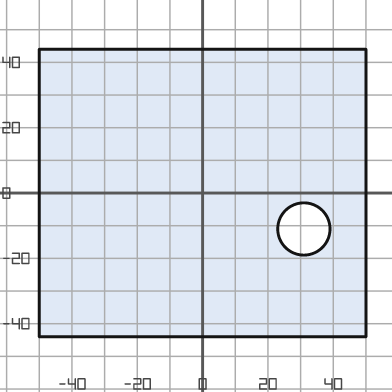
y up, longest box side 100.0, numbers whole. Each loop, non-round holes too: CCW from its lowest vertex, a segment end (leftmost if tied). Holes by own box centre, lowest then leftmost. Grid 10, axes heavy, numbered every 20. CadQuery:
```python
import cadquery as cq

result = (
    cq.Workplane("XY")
    .moveTo(-50.0, -44.0)
    .lineTo(50.0, -44.0)
    .lineTo(50.0, 44.0)
    .lineTo(-50.0, 44.0)
    .close()
    .moveTo(31.0, -11.0)
    .circle(8.0)
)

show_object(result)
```